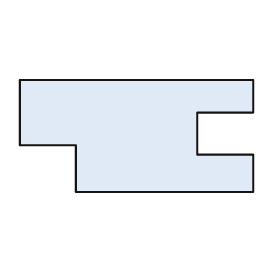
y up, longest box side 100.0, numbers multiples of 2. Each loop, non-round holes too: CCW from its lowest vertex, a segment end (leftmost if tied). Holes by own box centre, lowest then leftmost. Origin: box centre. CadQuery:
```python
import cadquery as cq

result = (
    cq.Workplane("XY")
    .moveTo(-26.0, -24.0)
    .lineTo(50.0, -24.0)
    .lineTo(50.0, -8.0)
    .lineTo(26.0, -8.0)
    .lineTo(26.0, 10.0)
    .lineTo(50.0, 10.0)
    .lineTo(50.0, 24.0)
    .lineTo(-50.0, 24.0)
    .lineTo(-50.0, -4.0)
    .lineTo(-26.0, -4.0)
    .close()
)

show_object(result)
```